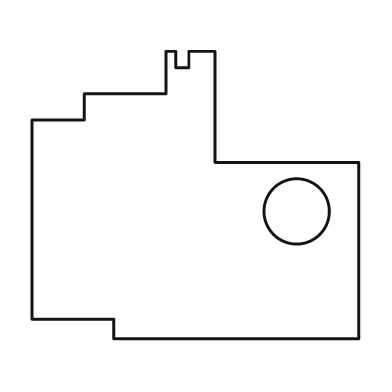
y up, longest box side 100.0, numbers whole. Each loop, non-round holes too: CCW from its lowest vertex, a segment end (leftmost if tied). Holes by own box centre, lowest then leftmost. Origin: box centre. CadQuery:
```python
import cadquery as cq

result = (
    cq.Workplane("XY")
    .moveTo(-25.0, -44.0)
    .lineTo(50.0, -44.0)
    .lineTo(50.0, 10.0)
    .lineTo(6.0, 10.0)
    .lineTo(6.0, 44.0)
    .lineTo(-2.0, 44.0)
    .lineTo(-2.0, 39.0)
    .lineTo(-6.0, 39.0)
    .lineTo(-6.0, 44.0)
    .lineTo(-9.0, 44.0)
    .lineTo(-9.0, 31.0)
    .lineTo(-34.0, 31.0)
    .lineTo(-34.0, 23.0)
    .lineTo(-50.0, 23.0)
    .lineTo(-50.0, -38.0)
    .lineTo(-25.0, -38.0)
    .close()
    .moveTo(31.0, -5.0)
    .circle(10.0)
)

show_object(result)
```